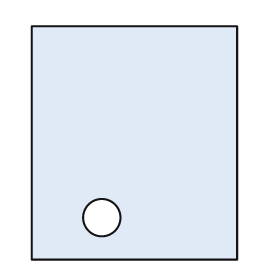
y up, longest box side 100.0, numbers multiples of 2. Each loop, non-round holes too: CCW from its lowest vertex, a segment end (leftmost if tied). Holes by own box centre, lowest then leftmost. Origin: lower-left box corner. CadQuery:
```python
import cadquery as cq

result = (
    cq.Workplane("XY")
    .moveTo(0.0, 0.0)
    .lineTo(88.0, 0.0)
    .lineTo(88.0, 100.0)
    .lineTo(0.0, 100.0)
    .close()
    .moveTo(30.0, 18.0)
    .circle(8.0)
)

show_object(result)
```